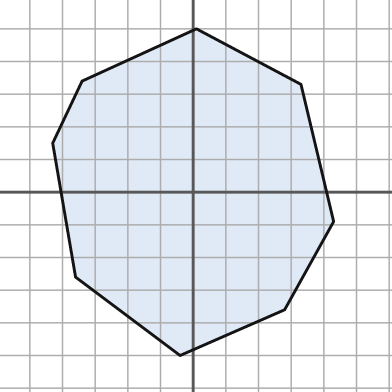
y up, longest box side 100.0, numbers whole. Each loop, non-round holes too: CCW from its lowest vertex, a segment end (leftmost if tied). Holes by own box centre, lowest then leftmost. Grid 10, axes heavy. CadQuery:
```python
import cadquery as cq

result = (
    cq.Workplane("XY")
    .moveTo(-4.0, -50.0)
    .lineTo(28.0, -36.0)
    .lineTo(43.0, -9.0)
    .lineTo(33.0, 33.0)
    .lineTo(1.0, 50.0)
    .lineTo(-34.0, 34.0)
    .lineTo(-43.0, 15.0)
    .lineTo(-36.0, -26.0)
    .close()
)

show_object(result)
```